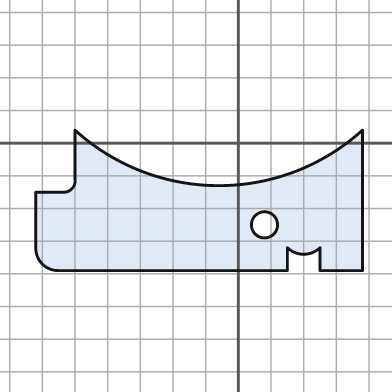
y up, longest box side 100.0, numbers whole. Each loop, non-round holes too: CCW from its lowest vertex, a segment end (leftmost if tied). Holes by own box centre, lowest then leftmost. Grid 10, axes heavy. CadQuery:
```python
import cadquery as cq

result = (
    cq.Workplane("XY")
    .moveTo(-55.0, -39.0)
    .lineTo(15.0, -39.0)
    .lineTo(15.0, -32.0)
    .threePointArc((20.0, -34.0), (25.0, -32.0))
    .lineTo(25.0, -39.0)
    .lineTo(38.0, -39.0)
    .lineTo(38.0, 4.0)
    .threePointArc((-6.0, -13.0), (-50.0, 4.0))
    .lineTo(-50.0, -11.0)
    .threePointArc((-51.0, -14.0), (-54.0, -15.0))
    .lineTo(-62.0, -15.0)
    .lineTo(-62.0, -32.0)
    .threePointArc((-60.0, -37.0), (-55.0, -39.0))
    .close()
    .moveTo(8.0, -25.0)
    .circle(4.0)
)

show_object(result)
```